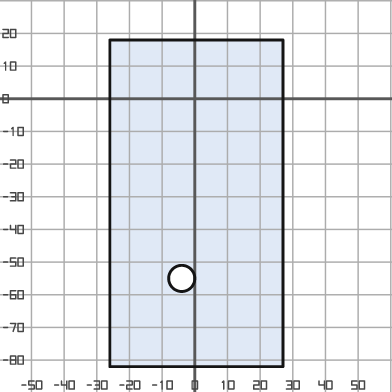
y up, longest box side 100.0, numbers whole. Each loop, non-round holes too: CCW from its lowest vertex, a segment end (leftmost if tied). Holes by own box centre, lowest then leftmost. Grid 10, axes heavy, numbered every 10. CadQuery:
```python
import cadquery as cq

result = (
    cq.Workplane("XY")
    .moveTo(-26.0, -82.0)
    .lineTo(27.0, -82.0)
    .lineTo(27.0, 18.0)
    .lineTo(-26.0, 18.0)
    .close()
    .moveTo(-4.0, -55.0)
    .circle(4.0)
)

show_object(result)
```